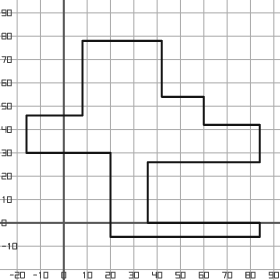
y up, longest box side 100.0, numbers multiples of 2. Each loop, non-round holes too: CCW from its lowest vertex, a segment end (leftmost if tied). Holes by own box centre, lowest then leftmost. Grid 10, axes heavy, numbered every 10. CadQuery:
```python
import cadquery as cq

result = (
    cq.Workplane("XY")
    .moveTo(20.0, -6.0)
    .lineTo(84.0, -6.0)
    .lineTo(84.0, 0.0)
    .lineTo(36.0, 0.0)
    .lineTo(36.0, 26.0)
    .lineTo(84.0, 26.0)
    .lineTo(84.0, 42.0)
    .lineTo(60.0, 42.0)
    .lineTo(60.0, 54.0)
    .lineTo(42.0, 54.0)
    .lineTo(42.0, 78.0)
    .lineTo(8.0, 78.0)
    .lineTo(8.0, 46.0)
    .lineTo(-16.0, 46.0)
    .lineTo(-16.0, 30.0)
    .lineTo(20.0, 30.0)
    .close()
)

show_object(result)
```